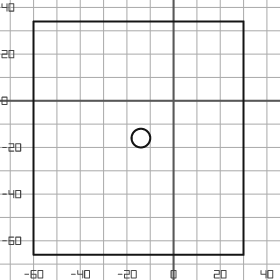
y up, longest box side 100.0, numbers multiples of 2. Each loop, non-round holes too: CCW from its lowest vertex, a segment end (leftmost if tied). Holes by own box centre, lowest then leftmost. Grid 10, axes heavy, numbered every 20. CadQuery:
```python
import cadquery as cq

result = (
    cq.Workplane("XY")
    .moveTo(-60.0, -66.0)
    .lineTo(30.0, -66.0)
    .lineTo(30.0, 34.0)
    .lineTo(-60.0, 34.0)
    .close()
    .moveTo(-14.0, -16.0)
    .circle(4.0)
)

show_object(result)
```